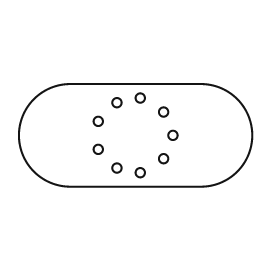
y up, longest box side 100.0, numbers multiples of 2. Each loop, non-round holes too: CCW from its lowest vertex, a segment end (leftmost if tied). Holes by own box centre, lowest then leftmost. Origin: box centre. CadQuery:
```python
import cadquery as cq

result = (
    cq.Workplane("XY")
    .moveTo(-28.0, -22.0)
    .lineTo(28.0, -22.0)
    .threePointArc((50.0, 0.0), (28.0, 22.0))
    .lineTo(-28.0, 22.0)
    .threePointArc((-50.0, 0.0), (-28.0, -22.0))
    .close()
    .moveTo(2.0, -16.0)
    .circle(2.0)
    .moveTo(-8.0, -14.0)
    .circle(2.0)
    .moveTo(12.0, -10.0)
    .circle(2.0)
    .moveTo(-16.0, -6.0)
    .circle(2.0)
    .moveTo(16.0, 0.0)
    .circle(2.0)
    .moveTo(-16.0, 6.0)
    .circle(2.0)
    .moveTo(12.0, 10.0)
    .circle(2.0)
    .moveTo(-8.0, 14.0)
    .circle(2.0)
    .moveTo(2.0, 16.0)
    .circle(2.0)
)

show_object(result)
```